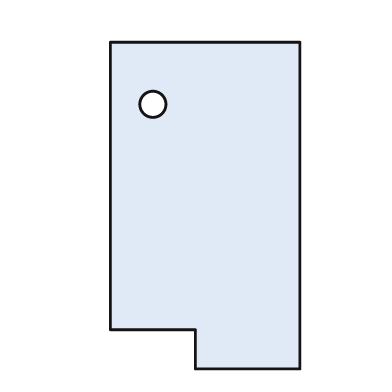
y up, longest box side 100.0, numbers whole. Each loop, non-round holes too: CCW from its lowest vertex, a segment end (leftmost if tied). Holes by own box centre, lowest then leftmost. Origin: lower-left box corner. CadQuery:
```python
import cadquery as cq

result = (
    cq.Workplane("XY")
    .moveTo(26.0, 0.0)
    .lineTo(58.0, 0.0)
    .lineTo(58.0, 100.0)
    .lineTo(0.0, 100.0)
    .lineTo(0.0, 12.0)
    .lineTo(26.0, 12.0)
    .close()
    .moveTo(13.0, 81.0)
    .circle(4.0)
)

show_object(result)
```